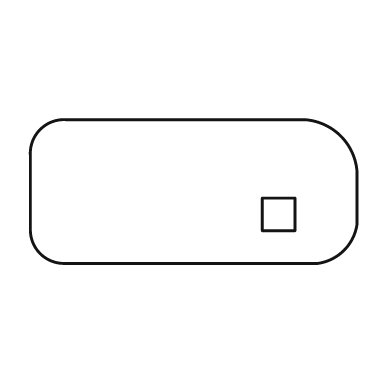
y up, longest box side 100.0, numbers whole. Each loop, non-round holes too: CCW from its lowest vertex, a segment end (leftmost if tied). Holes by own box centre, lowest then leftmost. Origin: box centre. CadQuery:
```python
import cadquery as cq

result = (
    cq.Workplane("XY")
    .moveTo(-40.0, -22.0)
    .lineTo(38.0, -22.0)
    .threePointArc((46.0, -18.0), (50.0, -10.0))
    .lineTo(50.0, 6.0)
    .threePointArc((45.0, 17.0), (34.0, 22.0))
    .lineTo(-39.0, 22.0)
    .threePointArc((-47.0, 19.0), (-50.0, 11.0))
    .lineTo(-50.0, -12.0)
    .threePointArc((-47.0, -19.0), (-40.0, -22.0))
    .close()
    .moveTo(21.0, -12.0)
    .lineTo(31.0, -12.0)
    .lineTo(31.0, -2.0)
    .lineTo(21.0, -2.0)
    .close()
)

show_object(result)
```